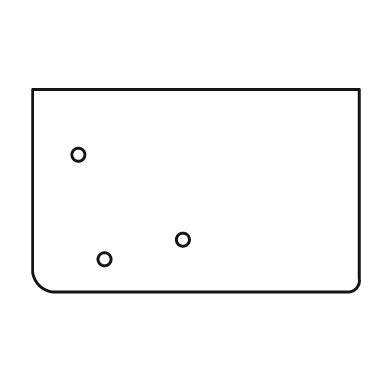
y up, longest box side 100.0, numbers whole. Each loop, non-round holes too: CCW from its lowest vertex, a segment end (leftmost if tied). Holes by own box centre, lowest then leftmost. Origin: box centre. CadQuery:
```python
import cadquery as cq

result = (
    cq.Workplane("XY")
    .moveTo(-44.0, -31.0)
    .lineTo(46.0, -31.0)
    .threePointArc((49.0, -30.0), (50.0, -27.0))
    .lineTo(50.0, 31.0)
    .lineTo(-50.0, 31.0)
    .lineTo(-50.0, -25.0)
    .threePointArc((-48.0, -29.0), (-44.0, -31.0))
    .close()
    .moveTo(-28.0, -21.0)
    .circle(2.0)
    .moveTo(-4.0, -15.0)
    .circle(2.0)
    .moveTo(-36.0, 11.0)
    .circle(2.0)
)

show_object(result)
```